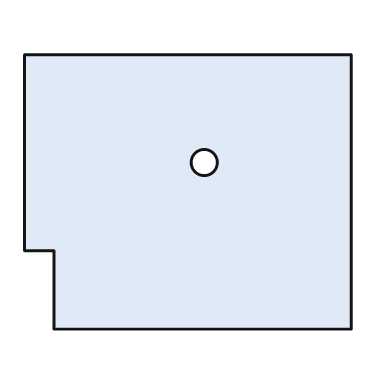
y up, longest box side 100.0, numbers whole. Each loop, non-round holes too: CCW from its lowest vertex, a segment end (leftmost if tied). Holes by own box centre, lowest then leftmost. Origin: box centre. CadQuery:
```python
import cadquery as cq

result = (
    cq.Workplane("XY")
    .moveTo(-41.0, -42.0)
    .lineTo(50.0, -42.0)
    .lineTo(50.0, 42.0)
    .lineTo(-50.0, 42.0)
    .lineTo(-50.0, -18.0)
    .lineTo(-41.0, -18.0)
    .close()
    .moveTo(5.0, 9.0)
    .circle(4.0)
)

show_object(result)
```